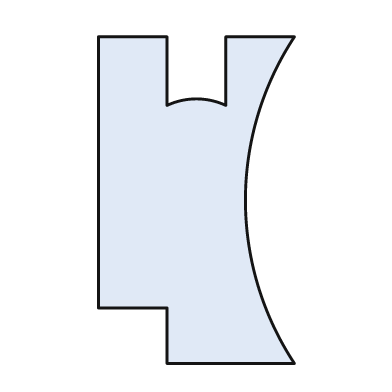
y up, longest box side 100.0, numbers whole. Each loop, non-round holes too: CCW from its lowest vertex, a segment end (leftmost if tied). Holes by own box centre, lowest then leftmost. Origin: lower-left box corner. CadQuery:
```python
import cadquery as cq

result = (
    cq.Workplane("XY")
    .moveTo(21.0, 0.0)
    .lineTo(60.0, 0.0)
    .threePointArc((45.0, 50.0), (60.0, 100.0))
    .lineTo(39.0, 100.0)
    .lineTo(39.0, 79.0)
    .threePointArc((30.0, 81.0), (21.0, 79.0))
    .lineTo(21.0, 100.0)
    .lineTo(0.0, 100.0)
    .lineTo(0.0, 17.0)
    .lineTo(21.0, 17.0)
    .close()
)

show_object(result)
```